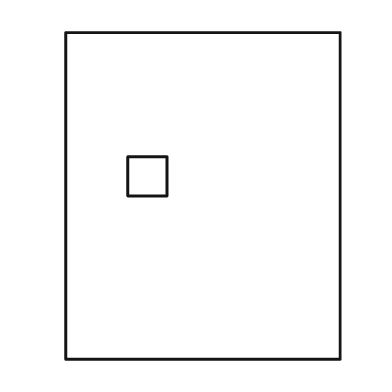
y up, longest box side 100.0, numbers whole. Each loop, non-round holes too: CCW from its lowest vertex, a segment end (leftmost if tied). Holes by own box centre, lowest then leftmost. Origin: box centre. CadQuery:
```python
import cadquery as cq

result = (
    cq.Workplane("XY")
    .moveTo(-42.0, -50.0)
    .lineTo(42.0, -50.0)
    .lineTo(42.0, 50.0)
    .lineTo(-42.0, 50.0)
    .close()
    .moveTo(-23.0, 0.0)
    .lineTo(-11.0, 0.0)
    .lineTo(-11.0, 12.0)
    .lineTo(-23.0, 12.0)
    .close()
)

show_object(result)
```